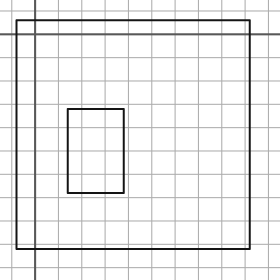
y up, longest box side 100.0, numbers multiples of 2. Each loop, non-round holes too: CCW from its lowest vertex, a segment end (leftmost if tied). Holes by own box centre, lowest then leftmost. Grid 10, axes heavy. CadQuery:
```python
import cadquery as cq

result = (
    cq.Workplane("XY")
    .moveTo(-8.0, -92.0)
    .lineTo(92.0, -92.0)
    .lineTo(92.0, 6.0)
    .lineTo(-8.0, 6.0)
    .close()
    .moveTo(14.0, -68.0)
    .lineTo(38.0, -68.0)
    .lineTo(38.0, -32.0)
    .lineTo(14.0, -32.0)
    .close()
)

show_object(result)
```